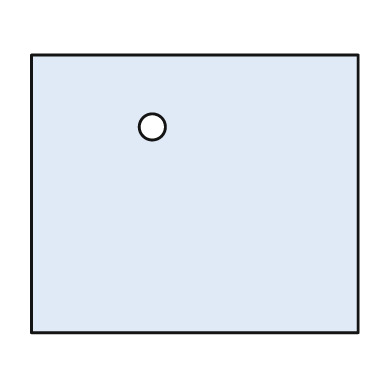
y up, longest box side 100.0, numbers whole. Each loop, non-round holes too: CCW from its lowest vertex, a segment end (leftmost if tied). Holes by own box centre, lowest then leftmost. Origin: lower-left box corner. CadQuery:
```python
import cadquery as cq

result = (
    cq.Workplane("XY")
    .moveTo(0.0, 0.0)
    .lineTo(100.0, 0.0)
    .lineTo(100.0, 85.0)
    .lineTo(0.0, 85.0)
    .close()
    .moveTo(37.0, 63.0)
    .circle(4.0)
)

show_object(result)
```